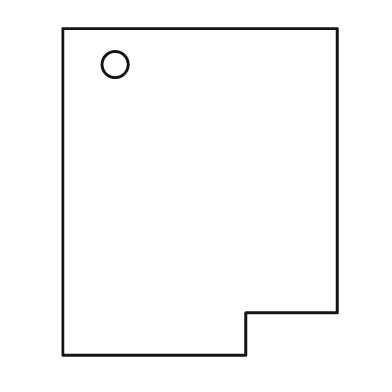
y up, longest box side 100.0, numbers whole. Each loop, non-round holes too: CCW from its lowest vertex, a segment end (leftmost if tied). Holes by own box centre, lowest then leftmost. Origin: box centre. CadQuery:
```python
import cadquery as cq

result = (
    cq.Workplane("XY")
    .moveTo(-42.0, -50.0)
    .lineTo(14.0, -50.0)
    .lineTo(14.0, -37.0)
    .lineTo(42.0, -37.0)
    .lineTo(42.0, 50.0)
    .lineTo(-42.0, 50.0)
    .close()
    .moveTo(-26.0, 39.0)
    .circle(4.0)
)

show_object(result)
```